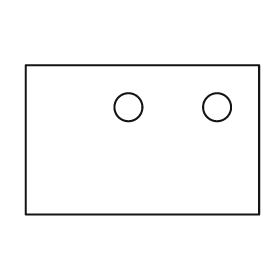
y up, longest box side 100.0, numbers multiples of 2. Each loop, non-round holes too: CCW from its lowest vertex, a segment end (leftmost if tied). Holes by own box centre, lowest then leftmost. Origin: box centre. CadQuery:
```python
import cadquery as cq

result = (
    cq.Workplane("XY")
    .moveTo(-50.0, -32.0)
    .lineTo(50.0, -32.0)
    .lineTo(50.0, 32.0)
    .lineTo(-50.0, 32.0)
    .close()
    .moveTo(-6.0, 14.0)
    .circle(6.0)
    .moveTo(32.0, 14.0)
    .circle(6.0)
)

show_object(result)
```